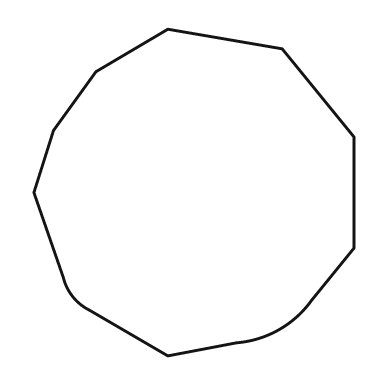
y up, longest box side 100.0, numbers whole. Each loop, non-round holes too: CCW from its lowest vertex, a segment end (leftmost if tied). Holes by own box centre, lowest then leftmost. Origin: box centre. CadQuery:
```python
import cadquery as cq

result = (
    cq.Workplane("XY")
    .moveTo(-8.0, -50.0)
    .lineTo(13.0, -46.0)
    .threePointArc((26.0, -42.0), (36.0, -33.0))
    .lineTo(49.0, -17.0)
    .lineTo(49.0, 17.0)
    .lineTo(27.0, 44.0)
    .lineTo(-8.0, 50.0)
    .lineTo(-30.0, 37.0)
    .lineTo(-43.0, 19.0)
    .lineTo(-49.0, 0.0)
    .lineTo(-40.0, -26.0)
    .threePointArc((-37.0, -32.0), (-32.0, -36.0))
    .close()
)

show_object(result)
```